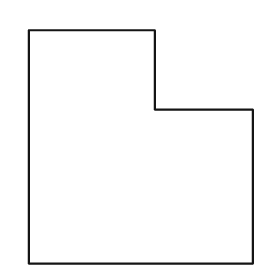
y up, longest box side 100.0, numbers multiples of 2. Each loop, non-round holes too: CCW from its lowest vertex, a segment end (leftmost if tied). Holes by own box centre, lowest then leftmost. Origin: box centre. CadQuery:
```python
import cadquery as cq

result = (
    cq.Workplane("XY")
    .moveTo(-48.0, -50.0)
    .lineTo(48.0, -50.0)
    .lineTo(48.0, 16.0)
    .lineTo(6.0, 16.0)
    .lineTo(6.0, 50.0)
    .lineTo(-48.0, 50.0)
    .close()
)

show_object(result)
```